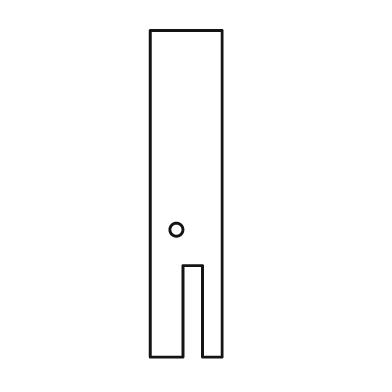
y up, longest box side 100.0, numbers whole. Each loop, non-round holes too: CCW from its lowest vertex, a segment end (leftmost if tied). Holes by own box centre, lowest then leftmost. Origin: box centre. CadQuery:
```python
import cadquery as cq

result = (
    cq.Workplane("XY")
    .moveTo(-11.0, -50.0)
    .lineTo(-1.0, -50.0)
    .lineTo(-1.0, -22.0)
    .lineTo(5.0, -22.0)
    .lineTo(5.0, -50.0)
    .lineTo(11.0, -50.0)
    .lineTo(11.0, 50.0)
    .lineTo(-11.0, 50.0)
    .close()
    .moveTo(-3.0, -11.0)
    .circle(2.0)
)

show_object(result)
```